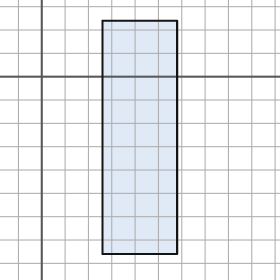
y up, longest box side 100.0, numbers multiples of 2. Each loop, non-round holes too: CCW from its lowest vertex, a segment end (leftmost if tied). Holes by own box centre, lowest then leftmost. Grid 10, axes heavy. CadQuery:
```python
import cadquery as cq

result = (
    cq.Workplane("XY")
    .moveTo(26.0, -76.0)
    .lineTo(58.0, -76.0)
    .lineTo(58.0, 24.0)
    .lineTo(26.0, 24.0)
    .close()
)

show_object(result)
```